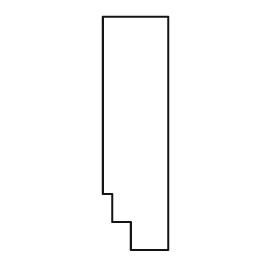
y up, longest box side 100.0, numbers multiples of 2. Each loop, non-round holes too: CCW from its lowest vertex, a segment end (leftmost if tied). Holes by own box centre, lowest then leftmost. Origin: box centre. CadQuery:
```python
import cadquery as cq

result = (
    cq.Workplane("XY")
    .moveTo(-2.0, -50.0)
    .lineTo(14.0, -50.0)
    .lineTo(14.0, 50.0)
    .lineTo(-14.0, 50.0)
    .lineTo(-14.0, -26.0)
    .lineTo(-10.0, -26.0)
    .lineTo(-10.0, -38.0)
    .lineTo(-2.0, -38.0)
    .close()
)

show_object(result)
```